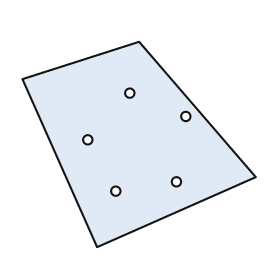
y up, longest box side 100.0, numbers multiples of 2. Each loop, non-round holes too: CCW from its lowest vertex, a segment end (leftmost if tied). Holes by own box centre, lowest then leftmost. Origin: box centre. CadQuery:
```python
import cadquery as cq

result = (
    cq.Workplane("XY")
    .moveTo(-18.0, -44.0)
    .lineTo(50.0, -14.0)
    .lineTo(0.0, 44.0)
    .lineTo(-50.0, 28.0)
    .close()
    .moveTo(-10.0, -20.0)
    .circle(2.0)
    .moveTo(16.0, -16.0)
    .circle(2.0)
    .moveTo(-22.0, 2.0)
    .circle(2.0)
    .moveTo(20.0, 12.0)
    .circle(2.0)
    .moveTo(-4.0, 22.0)
    .circle(2.0)
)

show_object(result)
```